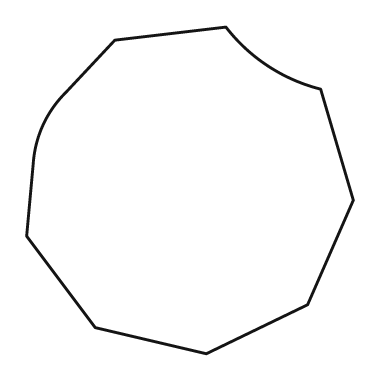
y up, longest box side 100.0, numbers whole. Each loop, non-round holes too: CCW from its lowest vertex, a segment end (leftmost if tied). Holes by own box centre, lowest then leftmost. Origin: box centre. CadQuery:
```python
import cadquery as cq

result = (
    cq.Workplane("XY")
    .moveTo(5.0, -50.0)
    .lineTo(36.0, -35.0)
    .lineTo(50.0, -3.0)
    .lineTo(40.0, 31.0)
    .threePointArc((24.0, 38.0), (11.0, 50.0))
    .lineTo(-23.0, 46.0)
    .lineTo(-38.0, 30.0)
    .threePointArc((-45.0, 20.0), (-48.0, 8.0))
    .lineTo(-50.0, -14.0)
    .lineTo(-29.0, -42.0)
    .close()
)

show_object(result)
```